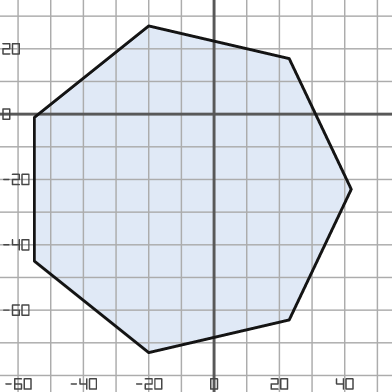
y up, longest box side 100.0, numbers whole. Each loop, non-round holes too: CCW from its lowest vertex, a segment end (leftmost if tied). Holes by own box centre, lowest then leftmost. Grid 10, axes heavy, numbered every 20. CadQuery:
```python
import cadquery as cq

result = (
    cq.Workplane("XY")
    .moveTo(-20.0, -73.0)
    .lineTo(23.0, -63.0)
    .lineTo(42.0, -23.0)
    .lineTo(23.0, 17.0)
    .lineTo(-20.0, 27.0)
    .lineTo(-55.0, -1.0)
    .lineTo(-55.0, -45.0)
    .close()
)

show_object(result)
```